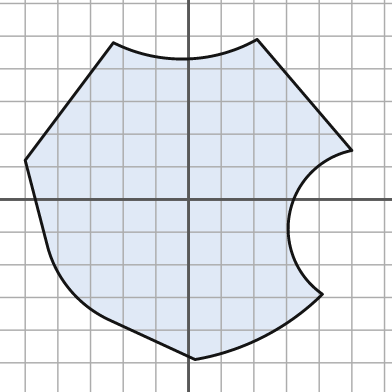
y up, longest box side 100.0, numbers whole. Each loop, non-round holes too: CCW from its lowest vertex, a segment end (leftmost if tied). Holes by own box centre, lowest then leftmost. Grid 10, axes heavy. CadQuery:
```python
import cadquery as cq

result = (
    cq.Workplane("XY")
    .moveTo(2.0, -49.0)
    .threePointArc((23.0, -42.0), (41.0, -29.0))
    .threePointArc((31.0, -4.0), (50.0, 15.0))
    .lineTo(21.0, 49.0)
    .threePointArc((-1.0, 43.0), (-23.0, 48.0))
    .lineTo(-50.0, 12.0)
    .lineTo(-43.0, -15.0)
    .threePointArc((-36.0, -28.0), (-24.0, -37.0))
    .close()
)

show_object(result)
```